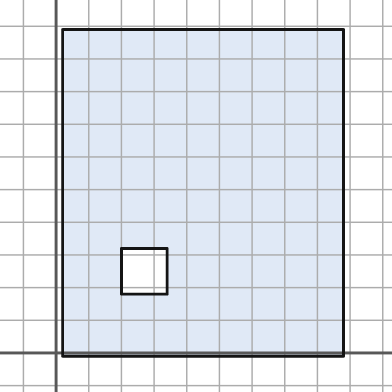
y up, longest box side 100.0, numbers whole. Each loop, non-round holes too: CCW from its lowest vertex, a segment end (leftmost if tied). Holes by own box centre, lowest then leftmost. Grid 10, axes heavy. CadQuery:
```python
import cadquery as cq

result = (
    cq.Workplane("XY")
    .moveTo(2.0, -1.0)
    .lineTo(88.0, -1.0)
    .lineTo(88.0, 99.0)
    .lineTo(2.0, 99.0)
    .close()
    .moveTo(20.0, 18.0)
    .lineTo(34.0, 18.0)
    .lineTo(34.0, 32.0)
    .lineTo(20.0, 32.0)
    .close()
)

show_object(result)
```